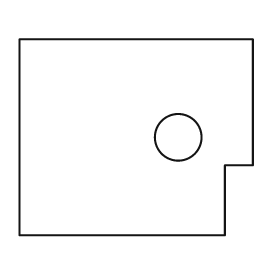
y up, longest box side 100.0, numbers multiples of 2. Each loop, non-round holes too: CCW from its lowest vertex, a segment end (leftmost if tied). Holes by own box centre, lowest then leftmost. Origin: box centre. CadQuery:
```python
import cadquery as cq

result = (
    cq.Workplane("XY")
    .moveTo(-50.0, -42.0)
    .lineTo(38.0, -42.0)
    .lineTo(38.0, -12.0)
    .lineTo(50.0, -12.0)
    .lineTo(50.0, 42.0)
    .lineTo(-50.0, 42.0)
    .close()
    .moveTo(18.0, 0.0)
    .circle(10.0)
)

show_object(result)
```